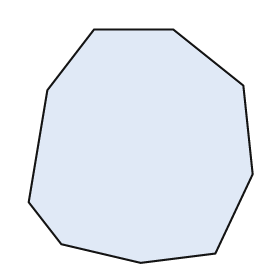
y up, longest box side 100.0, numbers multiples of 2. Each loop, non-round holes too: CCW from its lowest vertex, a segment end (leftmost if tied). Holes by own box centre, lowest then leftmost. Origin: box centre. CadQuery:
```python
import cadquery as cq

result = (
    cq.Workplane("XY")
    .moveTo(0.0, -50.0)
    .lineTo(32.0, -46.0)
    .lineTo(48.0, -12.0)
    .lineTo(44.0, 26.0)
    .lineTo(14.0, 50.0)
    .lineTo(-20.0, 50.0)
    .lineTo(-40.0, 24.0)
    .lineTo(-48.0, -24.0)
    .lineTo(-34.0, -42.0)
    .close()
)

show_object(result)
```